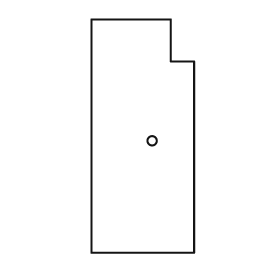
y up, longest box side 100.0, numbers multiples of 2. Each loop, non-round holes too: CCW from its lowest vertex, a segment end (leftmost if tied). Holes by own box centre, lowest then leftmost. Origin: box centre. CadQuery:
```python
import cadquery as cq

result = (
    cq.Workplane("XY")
    .moveTo(-22.0, -50.0)
    .lineTo(22.0, -50.0)
    .lineTo(22.0, 32.0)
    .lineTo(12.0, 32.0)
    .lineTo(12.0, 50.0)
    .lineTo(-22.0, 50.0)
    .close()
    .moveTo(4.0, -2.0)
    .circle(2.0)
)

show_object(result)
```